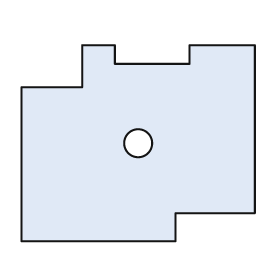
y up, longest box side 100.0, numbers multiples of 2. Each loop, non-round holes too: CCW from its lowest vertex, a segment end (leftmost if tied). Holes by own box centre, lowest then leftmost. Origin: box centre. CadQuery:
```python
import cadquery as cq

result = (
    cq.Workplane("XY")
    .moveTo(-50.0, -42.0)
    .lineTo(16.0, -42.0)
    .lineTo(16.0, -30.0)
    .lineTo(50.0, -30.0)
    .lineTo(50.0, 42.0)
    .lineTo(22.0, 42.0)
    .lineTo(22.0, 34.0)
    .lineTo(-10.0, 34.0)
    .lineTo(-10.0, 42.0)
    .lineTo(-24.0, 42.0)
    .lineTo(-24.0, 24.0)
    .lineTo(-50.0, 24.0)
    .close()
    .moveTo(0.0, 0.0)
    .circle(6.0)
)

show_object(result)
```